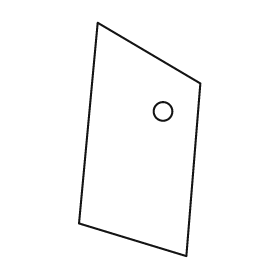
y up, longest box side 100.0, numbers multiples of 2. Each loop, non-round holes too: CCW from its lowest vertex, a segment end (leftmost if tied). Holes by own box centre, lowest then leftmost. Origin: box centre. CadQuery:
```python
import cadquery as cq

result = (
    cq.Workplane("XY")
    .moveTo(20.0, -50.0)
    .lineTo(26.0, 24.0)
    .lineTo(-18.0, 50.0)
    .lineTo(-26.0, -36.0)
    .close()
    .moveTo(10.0, 12.0)
    .circle(4.0)
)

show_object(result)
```